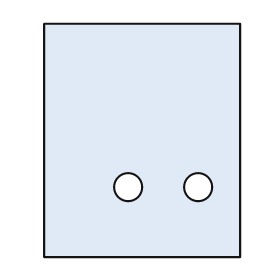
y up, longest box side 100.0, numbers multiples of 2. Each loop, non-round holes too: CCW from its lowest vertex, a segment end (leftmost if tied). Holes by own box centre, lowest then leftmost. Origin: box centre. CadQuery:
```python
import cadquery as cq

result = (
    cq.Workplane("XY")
    .moveTo(-42.0, -50.0)
    .lineTo(42.0, -50.0)
    .lineTo(42.0, 50.0)
    .lineTo(-42.0, 50.0)
    .close()
    .moveTo(-6.0, -20.0)
    .circle(6.0)
    .moveTo(24.0, -20.0)
    .circle(6.0)
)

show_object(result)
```